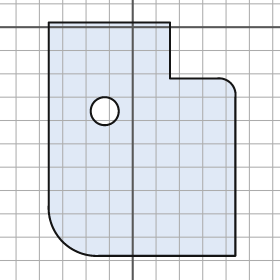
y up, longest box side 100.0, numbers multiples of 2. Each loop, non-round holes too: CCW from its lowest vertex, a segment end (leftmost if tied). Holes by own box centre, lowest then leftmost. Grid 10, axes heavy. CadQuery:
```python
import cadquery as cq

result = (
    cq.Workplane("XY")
    .moveTo(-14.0, -98.0)
    .lineTo(44.0, -98.0)
    .lineTo(44.0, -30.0)
    .threePointArc((42.0, -24.0), (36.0, -22.0))
    .lineTo(16.0, -22.0)
    .lineTo(16.0, 2.0)
    .lineTo(-36.0, 2.0)
    .lineTo(-36.0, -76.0)
    .threePointArc((-30.0, -92.0), (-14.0, -98.0))
    .close()
    .moveTo(-12.0, -36.0)
    .circle(6.0)
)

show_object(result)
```